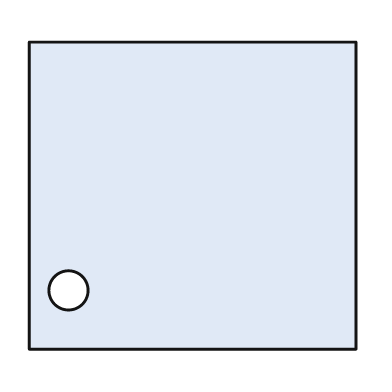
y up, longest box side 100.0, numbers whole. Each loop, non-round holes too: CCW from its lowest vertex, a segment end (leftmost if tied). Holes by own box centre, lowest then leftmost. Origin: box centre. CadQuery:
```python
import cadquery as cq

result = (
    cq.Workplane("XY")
    .moveTo(-50.0, -47.0)
    .lineTo(50.0, -47.0)
    .lineTo(50.0, 47.0)
    .lineTo(-50.0, 47.0)
    .close()
    .moveTo(-38.0, -29.0)
    .circle(6.0)
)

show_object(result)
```